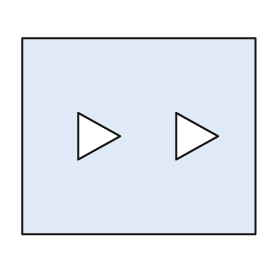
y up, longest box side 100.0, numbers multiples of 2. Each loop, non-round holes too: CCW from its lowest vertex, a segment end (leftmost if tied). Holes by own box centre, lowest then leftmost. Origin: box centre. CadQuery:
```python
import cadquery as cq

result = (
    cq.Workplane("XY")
    .moveTo(-50.0, -42.0)
    .lineTo(50.0, -42.0)
    .lineTo(50.0, 42.0)
    .lineTo(-50.0, 42.0)
    .close()
    .moveTo(-26.0, -10.0)
    .lineTo(-8.0, 0.0)
    .lineTo(-26.0, 10.0)
    .close()
    .moveTo(16.0, -10.0)
    .lineTo(34.0, 0.0)
    .lineTo(16.0, 10.0)
    .close()
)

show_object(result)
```